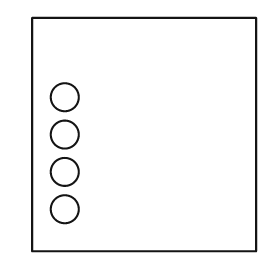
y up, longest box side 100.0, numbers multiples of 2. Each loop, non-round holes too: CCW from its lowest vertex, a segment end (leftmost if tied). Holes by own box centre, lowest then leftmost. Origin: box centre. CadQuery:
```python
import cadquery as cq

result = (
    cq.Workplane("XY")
    .moveTo(-48.0, -50.0)
    .lineTo(48.0, -50.0)
    .lineTo(48.0, 50.0)
    .lineTo(-48.0, 50.0)
    .close()
    .moveTo(-34.0, -32.0)
    .circle(6.0)
    .moveTo(-34.0, -16.0)
    .circle(6.0)
    .moveTo(-34.0, 0.0)
    .circle(6.0)
    .moveTo(-34.0, 16.0)
    .circle(6.0)
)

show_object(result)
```